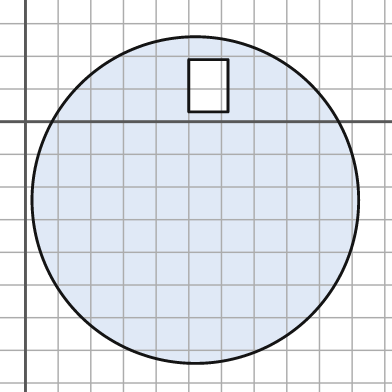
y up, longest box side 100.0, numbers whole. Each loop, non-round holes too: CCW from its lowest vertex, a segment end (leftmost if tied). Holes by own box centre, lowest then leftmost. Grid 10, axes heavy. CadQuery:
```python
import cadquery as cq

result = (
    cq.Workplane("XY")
    .moveTo(52.0, -24.0)
    .circle(50.0)
    .moveTo(50.0, 3.0)
    .lineTo(62.0, 3.0)
    .lineTo(62.0, 19.0)
    .lineTo(50.0, 19.0)
    .close()
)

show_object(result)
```